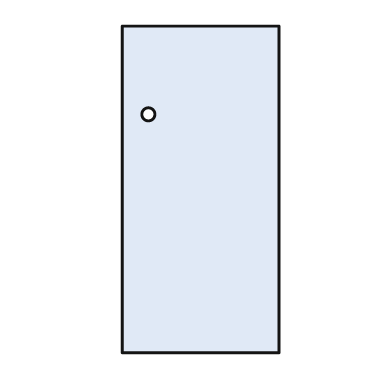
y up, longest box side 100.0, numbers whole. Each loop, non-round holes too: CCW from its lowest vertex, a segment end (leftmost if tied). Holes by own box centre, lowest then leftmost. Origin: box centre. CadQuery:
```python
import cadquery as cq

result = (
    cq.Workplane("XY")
    .moveTo(-24.0, -50.0)
    .lineTo(24.0, -50.0)
    .lineTo(24.0, 50.0)
    .lineTo(-24.0, 50.0)
    .close()
    .moveTo(-16.0, 23.0)
    .circle(2.0)
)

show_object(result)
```